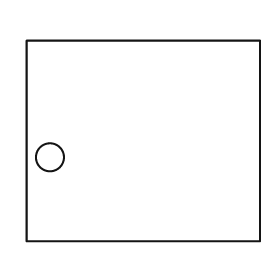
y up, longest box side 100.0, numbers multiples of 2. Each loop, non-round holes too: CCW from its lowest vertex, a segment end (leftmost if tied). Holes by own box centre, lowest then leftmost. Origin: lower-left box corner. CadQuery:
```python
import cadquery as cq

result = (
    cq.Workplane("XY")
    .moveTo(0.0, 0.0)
    .lineTo(100.0, 0.0)
    .lineTo(100.0, 86.0)
    .lineTo(0.0, 86.0)
    .close()
    .moveTo(10.0, 36.0)
    .circle(6.0)
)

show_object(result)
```